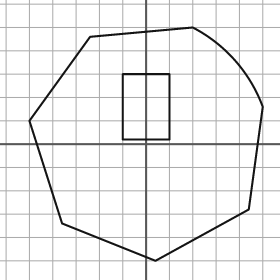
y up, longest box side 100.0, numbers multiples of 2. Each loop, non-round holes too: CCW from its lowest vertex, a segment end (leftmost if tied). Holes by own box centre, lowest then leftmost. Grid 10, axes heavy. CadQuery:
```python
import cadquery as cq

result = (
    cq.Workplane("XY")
    .moveTo(4.0, -50.0)
    .lineTo(44.0, -28.0)
    .lineTo(50.0, 16.0)
    .threePointArc((38.0, 36.0), (20.0, 50.0))
    .lineTo(-24.0, 46.0)
    .lineTo(-50.0, 10.0)
    .lineTo(-36.0, -34.0)
    .close()
    .moveTo(-10.0, 2.0)
    .lineTo(10.0, 2.0)
    .lineTo(10.0, 30.0)
    .lineTo(-10.0, 30.0)
    .close()
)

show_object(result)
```